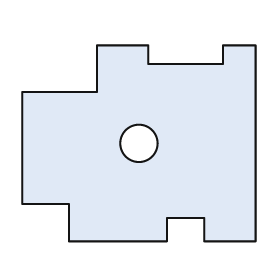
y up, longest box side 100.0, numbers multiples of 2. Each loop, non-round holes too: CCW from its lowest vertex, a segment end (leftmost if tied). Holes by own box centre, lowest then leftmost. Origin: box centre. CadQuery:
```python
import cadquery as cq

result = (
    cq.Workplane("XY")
    .moveTo(-30.0, -42.0)
    .lineTo(12.0, -42.0)
    .lineTo(12.0, -32.0)
    .lineTo(28.0, -32.0)
    .lineTo(28.0, -42.0)
    .lineTo(50.0, -42.0)
    .lineTo(50.0, 42.0)
    .lineTo(36.0, 42.0)
    .lineTo(36.0, 34.0)
    .lineTo(4.0, 34.0)
    .lineTo(4.0, 42.0)
    .lineTo(-18.0, 42.0)
    .lineTo(-18.0, 22.0)
    .lineTo(-50.0, 22.0)
    .lineTo(-50.0, -26.0)
    .lineTo(-30.0, -26.0)
    .close()
    .moveTo(0.0, 0.0)
    .circle(8.0)
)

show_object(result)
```